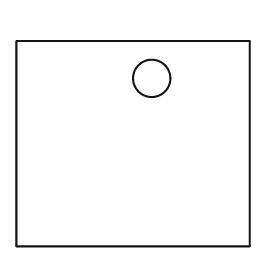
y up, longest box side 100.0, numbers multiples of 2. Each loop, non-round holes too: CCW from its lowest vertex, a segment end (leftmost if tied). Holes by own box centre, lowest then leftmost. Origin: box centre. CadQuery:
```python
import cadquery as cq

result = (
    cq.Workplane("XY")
    .moveTo(-50.0, -44.0)
    .lineTo(50.0, -44.0)
    .lineTo(50.0, 44.0)
    .lineTo(-50.0, 44.0)
    .close()
    .moveTo(8.0, 28.0)
    .circle(8.0)
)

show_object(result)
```